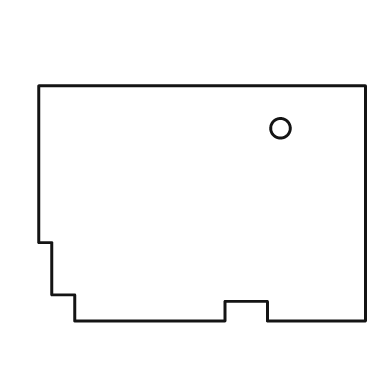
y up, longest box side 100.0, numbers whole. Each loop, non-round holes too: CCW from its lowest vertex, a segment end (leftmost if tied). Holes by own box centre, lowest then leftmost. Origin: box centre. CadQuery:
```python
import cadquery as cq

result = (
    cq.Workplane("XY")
    .moveTo(-39.0, -36.0)
    .lineTo(7.0, -36.0)
    .lineTo(7.0, -30.0)
    .lineTo(20.0, -30.0)
    .lineTo(20.0, -36.0)
    .lineTo(50.0, -36.0)
    .lineTo(50.0, 36.0)
    .lineTo(-50.0, 36.0)
    .lineTo(-50.0, -12.0)
    .lineTo(-46.0, -12.0)
    .lineTo(-46.0, -28.0)
    .lineTo(-39.0, -28.0)
    .close()
    .moveTo(24.0, 23.0)
    .circle(3.0)
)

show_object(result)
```